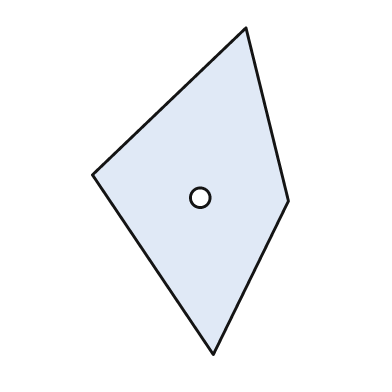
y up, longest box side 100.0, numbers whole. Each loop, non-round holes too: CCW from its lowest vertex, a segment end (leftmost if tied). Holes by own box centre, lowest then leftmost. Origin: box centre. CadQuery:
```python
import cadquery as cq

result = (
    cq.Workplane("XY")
    .moveTo(7.0, -50.0)
    .lineTo(30.0, -3.0)
    .lineTo(17.0, 50.0)
    .lineTo(-30.0, 5.0)
    .close()
    .moveTo(3.0, -2.0)
    .circle(3.0)
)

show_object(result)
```